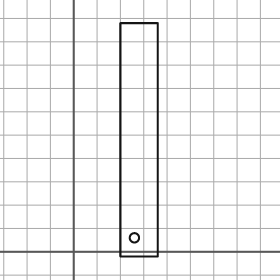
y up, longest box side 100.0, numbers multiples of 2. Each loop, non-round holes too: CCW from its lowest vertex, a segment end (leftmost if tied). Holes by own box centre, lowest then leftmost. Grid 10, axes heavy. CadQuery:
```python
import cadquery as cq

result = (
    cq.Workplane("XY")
    .moveTo(20.0, -2.0)
    .lineTo(36.0, -2.0)
    .lineTo(36.0, 98.0)
    .lineTo(20.0, 98.0)
    .close()
    .moveTo(26.0, 6.0)
    .circle(2.0)
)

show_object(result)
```